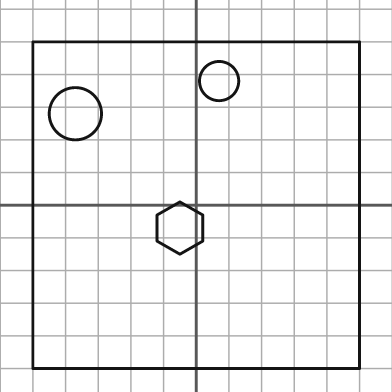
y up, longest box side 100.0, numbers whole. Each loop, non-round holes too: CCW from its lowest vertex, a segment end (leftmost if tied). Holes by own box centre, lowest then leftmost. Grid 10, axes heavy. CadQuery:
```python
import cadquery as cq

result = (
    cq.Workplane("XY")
    .moveTo(-50.0, -50.0)
    .lineTo(50.0, -50.0)
    .lineTo(50.0, 50.0)
    .lineTo(-50.0, 50.0)
    .close()
    .moveTo(-5.0, -15.0)
    .lineTo(2.0, -11.0)
    .lineTo(2.0, -3.0)
    .lineTo(-5.0, 1.0)
    .lineTo(-12.0, -3.0)
    .lineTo(-12.0, -11.0)
    .close()
    .moveTo(-37.0, 28.0)
    .circle(8.0)
    .moveTo(7.0, 38.0)
    .circle(6.0)
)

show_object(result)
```